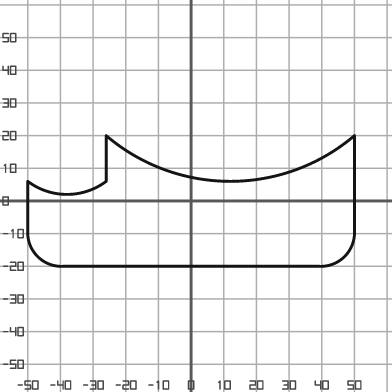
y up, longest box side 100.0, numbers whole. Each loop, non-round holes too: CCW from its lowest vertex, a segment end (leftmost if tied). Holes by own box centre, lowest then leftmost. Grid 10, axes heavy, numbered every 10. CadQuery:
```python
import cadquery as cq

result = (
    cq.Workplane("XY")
    .moveTo(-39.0, -20.0)
    .lineTo(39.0, -20.0)
    .threePointArc((47.0, -17.0), (50.0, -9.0))
    .lineTo(50.0, 20.0)
    .threePointArc((12.0, 6.0), (-26.0, 20.0))
    .lineTo(-26.0, 6.0)
    .threePointArc((-38.0, 2.0), (-50.0, 6.0))
    .lineTo(-50.0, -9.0)
    .threePointArc((-47.0, -17.0), (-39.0, -20.0))
    .close()
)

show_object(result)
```